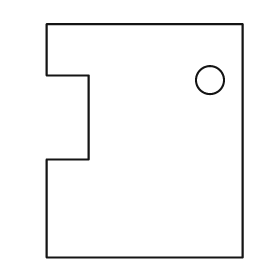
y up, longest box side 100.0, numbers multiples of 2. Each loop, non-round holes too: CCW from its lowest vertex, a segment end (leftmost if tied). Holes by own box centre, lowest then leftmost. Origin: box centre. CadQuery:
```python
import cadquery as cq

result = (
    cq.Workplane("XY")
    .moveTo(-42.0, -50.0)
    .lineTo(42.0, -50.0)
    .lineTo(42.0, 50.0)
    .lineTo(-42.0, 50.0)
    .lineTo(-42.0, 28.0)
    .lineTo(-24.0, 28.0)
    .lineTo(-24.0, -8.0)
    .lineTo(-42.0, -8.0)
    .close()
    .moveTo(28.0, 26.0)
    .circle(6.0)
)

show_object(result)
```